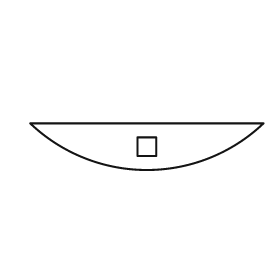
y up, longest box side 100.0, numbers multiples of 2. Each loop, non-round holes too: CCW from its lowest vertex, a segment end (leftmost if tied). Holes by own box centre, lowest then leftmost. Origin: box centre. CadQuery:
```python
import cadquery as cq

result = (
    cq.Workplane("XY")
    .moveTo(-50.0, 10.0)
    .threePointArc((0.0, -10.0), (50.0, 10.0))
    .close()
    .moveTo(-4.0, -4.0)
    .lineTo(4.0, -4.0)
    .lineTo(4.0, 4.0)
    .lineTo(-4.0, 4.0)
    .close()
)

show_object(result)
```